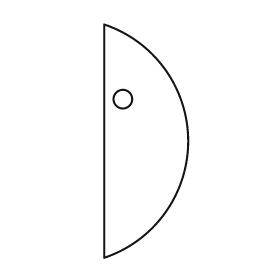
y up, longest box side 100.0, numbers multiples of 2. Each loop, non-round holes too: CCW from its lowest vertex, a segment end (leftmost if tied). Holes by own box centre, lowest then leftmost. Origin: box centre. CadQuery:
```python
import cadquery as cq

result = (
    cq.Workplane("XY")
    .moveTo(-18.0, -50.0)
    .threePointArc((18.0, 0.0), (-18.0, 50.0))
    .close()
    .moveTo(-10.0, 18.0)
    .circle(4.0)
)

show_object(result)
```